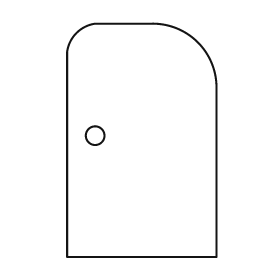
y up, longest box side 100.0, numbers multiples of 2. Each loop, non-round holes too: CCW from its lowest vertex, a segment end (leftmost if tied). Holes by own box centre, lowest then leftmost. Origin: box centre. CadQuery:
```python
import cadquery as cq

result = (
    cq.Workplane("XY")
    .moveTo(-32.0, -50.0)
    .lineTo(32.0, -50.0)
    .lineTo(32.0, 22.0)
    .threePointArc((24.0, 42.0), (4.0, 50.0))
    .lineTo(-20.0, 50.0)
    .threePointArc((-28.0, 46.0), (-32.0, 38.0))
    .close()
    .moveTo(-20.0, 2.0)
    .circle(4.0)
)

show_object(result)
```